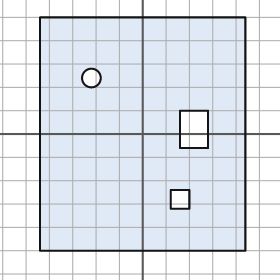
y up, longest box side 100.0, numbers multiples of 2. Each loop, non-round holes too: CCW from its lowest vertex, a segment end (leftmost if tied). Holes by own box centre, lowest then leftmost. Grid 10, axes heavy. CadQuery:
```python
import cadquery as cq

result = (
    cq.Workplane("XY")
    .moveTo(-44.0, -50.0)
    .lineTo(44.0, -50.0)
    .lineTo(44.0, 50.0)
    .lineTo(-44.0, 50.0)
    .close()
    .moveTo(12.0, -32.0)
    .lineTo(20.0, -32.0)
    .lineTo(20.0, -24.0)
    .lineTo(12.0, -24.0)
    .close()
    .moveTo(16.0, -6.0)
    .lineTo(28.0, -6.0)
    .lineTo(28.0, 10.0)
    .lineTo(16.0, 10.0)
    .close()
    .moveTo(-22.0, 24.0)
    .circle(4.0)
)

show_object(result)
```